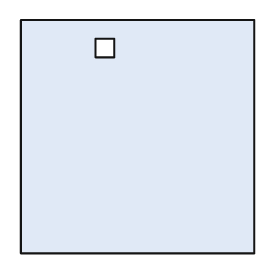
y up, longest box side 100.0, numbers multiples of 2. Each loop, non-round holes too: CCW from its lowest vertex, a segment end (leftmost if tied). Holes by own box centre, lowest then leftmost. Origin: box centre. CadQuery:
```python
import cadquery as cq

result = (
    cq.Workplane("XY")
    .moveTo(-50.0, -50.0)
    .lineTo(50.0, -50.0)
    .lineTo(50.0, 50.0)
    .lineTo(-50.0, 50.0)
    .close()
    .moveTo(-18.0, 34.0)
    .lineTo(-10.0, 34.0)
    .lineTo(-10.0, 42.0)
    .lineTo(-18.0, 42.0)
    .close()
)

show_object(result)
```